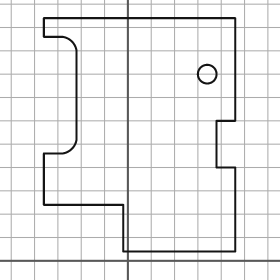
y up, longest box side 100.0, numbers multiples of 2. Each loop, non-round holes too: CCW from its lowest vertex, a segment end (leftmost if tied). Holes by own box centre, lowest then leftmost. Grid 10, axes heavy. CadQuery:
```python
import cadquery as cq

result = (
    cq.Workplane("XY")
    .moveTo(-2.0, 4.0)
    .lineTo(46.0, 4.0)
    .lineTo(46.0, 40.0)
    .lineTo(38.0, 40.0)
    .lineTo(38.0, 60.0)
    .lineTo(46.0, 60.0)
    .lineTo(46.0, 104.0)
    .lineTo(-36.0, 104.0)
    .lineTo(-36.0, 96.0)
    .lineTo(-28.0, 96.0)
    .threePointArc((-24.0, 94.0), (-22.0, 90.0))
    .lineTo(-22.0, 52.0)
    .threePointArc((-24.0, 48.0), (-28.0, 46.0))
    .lineTo(-36.0, 46.0)
    .lineTo(-36.0, 24.0)
    .lineTo(-2.0, 24.0)
    .close()
    .moveTo(34.0, 80.0)
    .circle(4.0)
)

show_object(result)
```